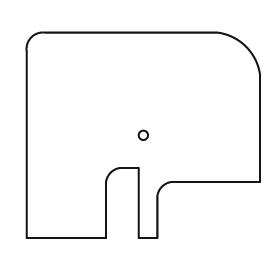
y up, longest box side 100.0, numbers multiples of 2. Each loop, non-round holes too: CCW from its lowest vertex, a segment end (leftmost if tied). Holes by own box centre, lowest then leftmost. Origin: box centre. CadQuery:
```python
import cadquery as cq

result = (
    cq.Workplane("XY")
    .moveTo(-50.0, -44.0)
    .lineTo(-16.0, -44.0)
    .lineTo(-16.0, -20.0)
    .threePointArc((-14.0, -16.0), (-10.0, -14.0))
    .lineTo(-2.0, -14.0)
    .lineTo(-2.0, -44.0)
    .lineTo(6.0, -44.0)
    .lineTo(6.0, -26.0)
    .threePointArc((8.0, -22.0), (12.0, -20.0))
    .lineTo(50.0, -20.0)
    .lineTo(50.0, 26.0)
    .threePointArc((44.0, 38.0), (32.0, 44.0))
    .lineTo(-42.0, 44.0)
    .threePointArc((-48.0, 42.0), (-50.0, 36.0))
    .close()
    .moveTo(0.0, 0.0)
    .circle(2.0)
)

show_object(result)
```